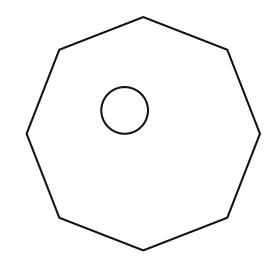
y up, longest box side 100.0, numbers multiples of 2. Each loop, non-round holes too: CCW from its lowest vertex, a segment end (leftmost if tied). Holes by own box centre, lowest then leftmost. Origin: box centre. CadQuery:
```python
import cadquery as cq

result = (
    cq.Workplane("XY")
    .moveTo(0.0, -50.0)
    .lineTo(36.0, -36.0)
    .lineTo(50.0, 0.0)
    .lineTo(36.0, 36.0)
    .lineTo(0.0, 50.0)
    .lineTo(-36.0, 36.0)
    .lineTo(-50.0, 0.0)
    .lineTo(-36.0, -36.0)
    .close()
    .moveTo(-8.0, 10.0)
    .circle(10.0)
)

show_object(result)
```